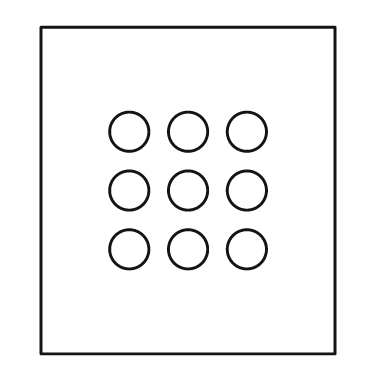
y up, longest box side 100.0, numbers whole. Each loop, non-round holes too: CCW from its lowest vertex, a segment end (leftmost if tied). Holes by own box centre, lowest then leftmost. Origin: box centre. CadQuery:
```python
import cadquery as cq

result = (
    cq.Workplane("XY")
    .moveTo(-45.0, -50.0)
    .lineTo(45.0, -50.0)
    .lineTo(45.0, 50.0)
    .lineTo(-45.0, 50.0)
    .close()
    .moveTo(-18.0, -18.0)
    .circle(6.0)
    .moveTo(0.0, -18.0)
    .circle(6.0)
    .moveTo(18.0, -18.0)
    .circle(6.0)
    .moveTo(-18.0, 0.0)
    .circle(6.0)
    .moveTo(0.0, 0.0)
    .circle(6.0)
    .moveTo(18.0, 0.0)
    .circle(6.0)
    .moveTo(-18.0, 18.0)
    .circle(6.0)
    .moveTo(0.0, 18.0)
    .circle(6.0)
    .moveTo(18.0, 18.0)
    .circle(6.0)
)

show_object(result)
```